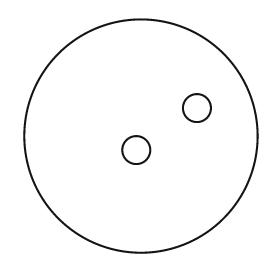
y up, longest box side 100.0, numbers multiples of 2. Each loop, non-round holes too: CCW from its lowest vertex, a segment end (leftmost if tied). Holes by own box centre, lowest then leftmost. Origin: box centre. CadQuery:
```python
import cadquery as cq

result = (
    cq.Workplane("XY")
    .moveTo(0.0, 0.0)
    .circle(50.0)
    .moveTo(-2.0, -6.0)
    .circle(6.0)
    .moveTo(24.0, 12.0)
    .circle(6.0)
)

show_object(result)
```